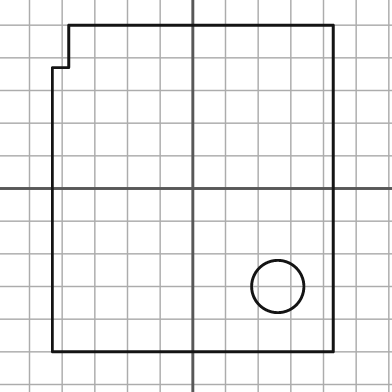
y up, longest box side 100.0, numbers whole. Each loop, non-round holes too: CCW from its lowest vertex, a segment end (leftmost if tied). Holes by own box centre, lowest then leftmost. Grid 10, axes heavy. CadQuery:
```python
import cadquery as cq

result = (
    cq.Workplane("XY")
    .moveTo(-43.0, -50.0)
    .lineTo(43.0, -50.0)
    .lineTo(43.0, 50.0)
    .lineTo(-38.0, 50.0)
    .lineTo(-38.0, 37.0)
    .lineTo(-43.0, 37.0)
    .close()
    .moveTo(26.0, -30.0)
    .circle(8.0)
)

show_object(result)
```